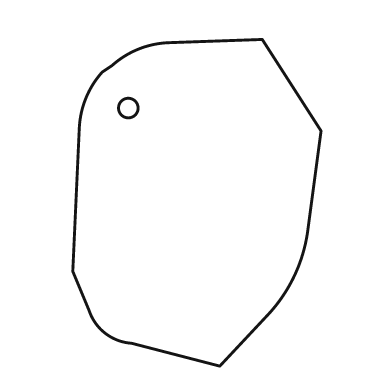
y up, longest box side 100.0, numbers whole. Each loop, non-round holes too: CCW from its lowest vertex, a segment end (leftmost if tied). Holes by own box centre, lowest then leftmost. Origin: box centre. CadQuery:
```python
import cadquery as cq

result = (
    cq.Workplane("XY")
    .moveTo(7.0, -50.0)
    .lineTo(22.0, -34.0)
    .threePointArc((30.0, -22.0), (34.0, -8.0))
    .lineTo(38.0, 22.0)
    .lineTo(20.0, 50.0)
    .lineTo(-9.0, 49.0)
    .threePointArc((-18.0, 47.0), (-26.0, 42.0))
    .lineTo(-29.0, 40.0)
    .threePointArc((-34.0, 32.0), (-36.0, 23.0))
    .lineTo(-38.0, -21.0)
    .lineTo(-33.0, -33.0)
    .threePointArc((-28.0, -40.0), (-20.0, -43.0))
    .close()
    .moveTo(-21.0, 29.0)
    .circle(3.0)
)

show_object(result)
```